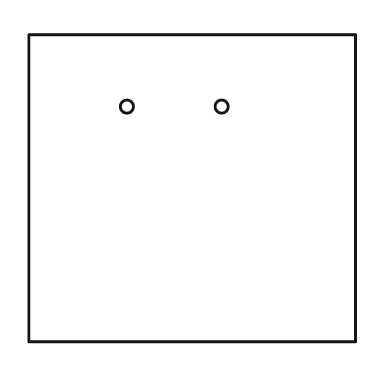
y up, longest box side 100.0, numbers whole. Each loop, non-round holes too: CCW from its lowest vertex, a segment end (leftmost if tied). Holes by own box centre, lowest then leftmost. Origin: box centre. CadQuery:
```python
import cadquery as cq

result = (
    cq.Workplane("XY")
    .moveTo(-50.0, -47.0)
    .lineTo(50.0, -47.0)
    .lineTo(50.0, 47.0)
    .lineTo(-50.0, 47.0)
    .close()
    .moveTo(-20.0, 25.0)
    .circle(2.0)
    .moveTo(9.0, 25.0)
    .circle(2.0)
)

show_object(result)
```